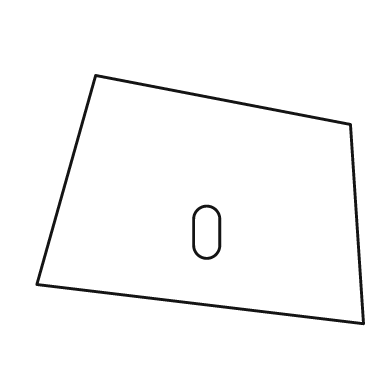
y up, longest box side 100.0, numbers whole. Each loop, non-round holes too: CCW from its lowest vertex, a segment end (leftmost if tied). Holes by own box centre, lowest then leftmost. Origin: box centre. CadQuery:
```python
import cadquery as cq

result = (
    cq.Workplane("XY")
    .moveTo(50.0, -38.0)
    .lineTo(46.0, 23.0)
    .lineTo(-32.0, 38.0)
    .lineTo(-50.0, -26.0)
    .close()
    .moveTo(-2.0, -14.0)
    .threePointArc((2.0, -18.0), (6.0, -14.0))
    .lineTo(6.0, -6.0)
    .threePointArc((2.0, -2.0), (-2.0, -6.0))
    .close()
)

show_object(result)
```